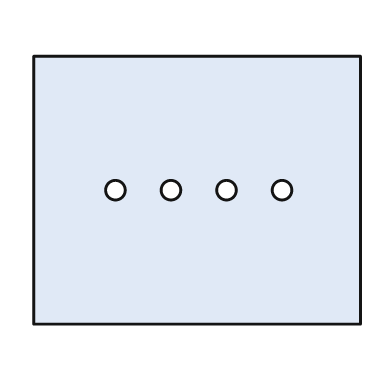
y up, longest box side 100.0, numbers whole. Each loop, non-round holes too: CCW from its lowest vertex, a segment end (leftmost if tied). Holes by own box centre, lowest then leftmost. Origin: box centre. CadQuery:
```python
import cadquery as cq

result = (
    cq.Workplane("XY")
    .moveTo(-50.0, -41.0)
    .lineTo(50.0, -41.0)
    .lineTo(50.0, 41.0)
    .lineTo(-50.0, 41.0)
    .close()
    .moveTo(-25.0, 0.0)
    .circle(3.0)
    .moveTo(-8.0, 0.0)
    .circle(3.0)
    .moveTo(9.0, 0.0)
    .circle(3.0)
    .moveTo(26.0, 0.0)
    .circle(3.0)
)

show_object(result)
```